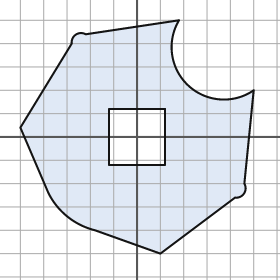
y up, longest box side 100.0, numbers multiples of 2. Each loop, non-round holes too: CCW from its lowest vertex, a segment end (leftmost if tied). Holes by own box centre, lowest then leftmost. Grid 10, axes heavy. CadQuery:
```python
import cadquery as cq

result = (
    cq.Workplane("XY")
    .moveTo(10.0, -50.0)
    .lineTo(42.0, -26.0)
    .threePointArc((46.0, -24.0), (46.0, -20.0))
    .lineTo(50.0, 20.0)
    .threePointArc((22.0, 22.0), (18.0, 50.0))
    .lineTo(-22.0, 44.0)
    .threePointArc((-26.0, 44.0), (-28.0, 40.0))
    .lineTo(-50.0, 4.0)
    .lineTo(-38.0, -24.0)
    .threePointArc((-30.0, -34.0), (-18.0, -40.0))
    .close()
    .moveTo(-12.0, -12.0)
    .lineTo(12.0, -12.0)
    .lineTo(12.0, 12.0)
    .lineTo(-12.0, 12.0)
    .close()
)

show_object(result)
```